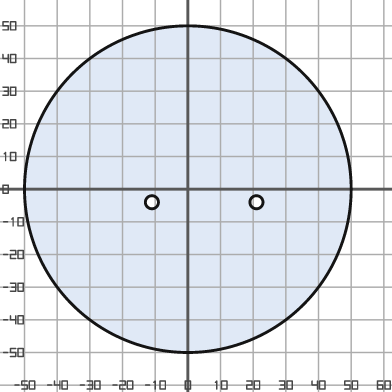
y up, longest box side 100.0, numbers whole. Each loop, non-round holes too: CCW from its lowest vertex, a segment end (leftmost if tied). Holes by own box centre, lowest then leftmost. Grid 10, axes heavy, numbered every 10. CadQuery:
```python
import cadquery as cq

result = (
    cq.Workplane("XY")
    .moveTo(0.0, 0.0)
    .circle(50.0)
    .moveTo(-11.0, -4.0)
    .circle(2.0)
    .moveTo(21.0, -4.0)
    .circle(2.0)
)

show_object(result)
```